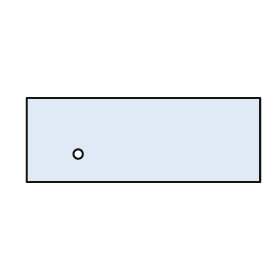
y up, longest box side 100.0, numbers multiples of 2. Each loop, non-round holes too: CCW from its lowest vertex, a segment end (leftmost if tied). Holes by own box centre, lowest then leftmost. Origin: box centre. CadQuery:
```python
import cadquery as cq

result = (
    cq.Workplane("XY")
    .moveTo(-50.0, -18.0)
    .lineTo(50.0, -18.0)
    .lineTo(50.0, 18.0)
    .lineTo(-50.0, 18.0)
    .close()
    .moveTo(-28.0, -6.0)
    .circle(2.0)
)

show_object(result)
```